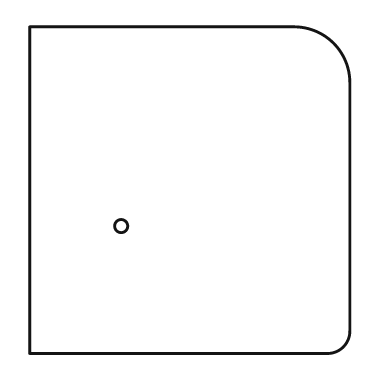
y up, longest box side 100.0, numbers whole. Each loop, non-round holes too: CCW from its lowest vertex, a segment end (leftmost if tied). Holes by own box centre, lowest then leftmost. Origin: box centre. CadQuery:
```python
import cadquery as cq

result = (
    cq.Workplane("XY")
    .moveTo(-49.0, -50.0)
    .lineTo(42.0, -50.0)
    .threePointArc((47.0, -48.0), (49.0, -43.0))
    .lineTo(49.0, 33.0)
    .threePointArc((44.0, 45.0), (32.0, 50.0))
    .lineTo(-49.0, 50.0)
    .close()
    .moveTo(-21.0, -11.0)
    .circle(2.0)
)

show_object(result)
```